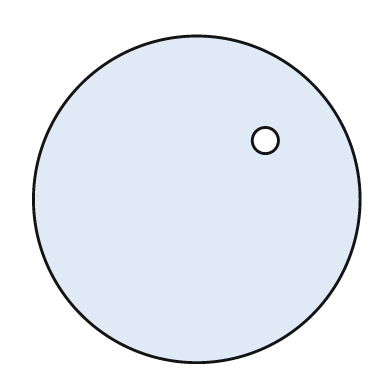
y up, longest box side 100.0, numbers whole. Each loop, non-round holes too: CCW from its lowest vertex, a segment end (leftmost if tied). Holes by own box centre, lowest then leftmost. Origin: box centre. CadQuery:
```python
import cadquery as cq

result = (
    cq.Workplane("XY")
    .moveTo(0.0, 0.0)
    .circle(50.0)
    .moveTo(21.0, 18.0)
    .circle(4.0)
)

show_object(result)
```